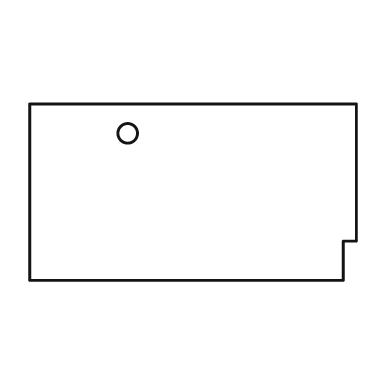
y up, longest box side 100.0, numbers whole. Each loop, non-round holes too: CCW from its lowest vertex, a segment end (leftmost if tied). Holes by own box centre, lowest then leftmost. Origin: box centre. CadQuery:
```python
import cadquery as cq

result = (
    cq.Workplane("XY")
    .moveTo(-50.0, -27.0)
    .lineTo(46.0, -27.0)
    .lineTo(46.0, -15.0)
    .lineTo(50.0, -15.0)
    .lineTo(50.0, 27.0)
    .lineTo(-50.0, 27.0)
    .close()
    .moveTo(-20.0, 18.0)
    .circle(3.0)
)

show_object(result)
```